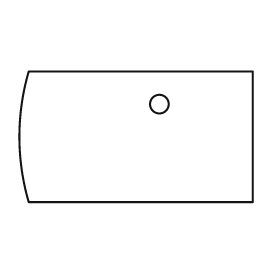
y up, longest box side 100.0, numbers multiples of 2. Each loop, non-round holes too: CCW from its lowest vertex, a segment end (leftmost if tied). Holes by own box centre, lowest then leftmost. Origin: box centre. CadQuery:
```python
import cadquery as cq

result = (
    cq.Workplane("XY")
    .moveTo(-46.0, -28.0)
    .lineTo(50.0, -28.0)
    .lineTo(50.0, 28.0)
    .lineTo(-46.0, 28.0)
    .threePointArc((-50.0, 0.0), (-46.0, -28.0))
    .close()
    .moveTo(10.0, 14.0)
    .circle(4.0)
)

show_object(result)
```